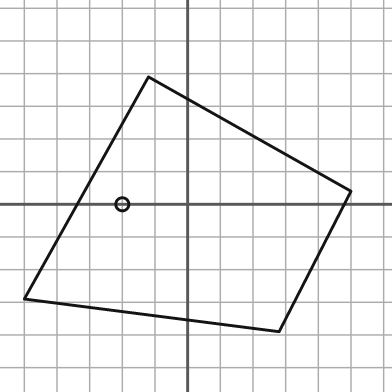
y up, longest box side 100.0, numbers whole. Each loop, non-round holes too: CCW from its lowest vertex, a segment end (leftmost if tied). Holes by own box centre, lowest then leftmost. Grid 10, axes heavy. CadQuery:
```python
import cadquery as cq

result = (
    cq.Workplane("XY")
    .moveTo(28.0, -39.0)
    .lineTo(50.0, 4.0)
    .lineTo(-12.0, 39.0)
    .lineTo(-50.0, -29.0)
    .close()
    .moveTo(-20.0, 0.0)
    .circle(2.0)
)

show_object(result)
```